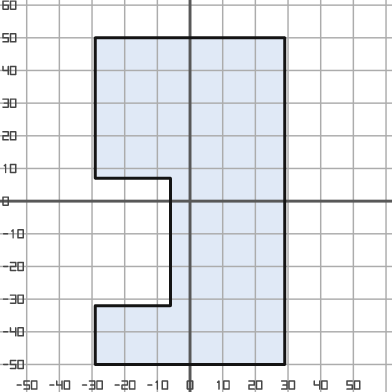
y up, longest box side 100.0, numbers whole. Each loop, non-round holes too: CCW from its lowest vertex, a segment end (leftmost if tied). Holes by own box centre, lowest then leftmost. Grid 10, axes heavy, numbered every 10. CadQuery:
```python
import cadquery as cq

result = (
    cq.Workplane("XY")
    .moveTo(-29.0, -50.0)
    .lineTo(29.0, -50.0)
    .lineTo(29.0, 50.0)
    .lineTo(-29.0, 50.0)
    .lineTo(-29.0, 7.0)
    .lineTo(-6.0, 7.0)
    .lineTo(-6.0, -32.0)
    .lineTo(-29.0, -32.0)
    .close()
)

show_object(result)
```